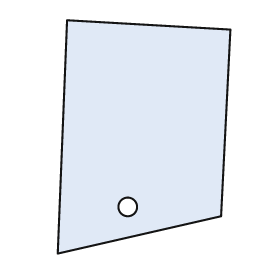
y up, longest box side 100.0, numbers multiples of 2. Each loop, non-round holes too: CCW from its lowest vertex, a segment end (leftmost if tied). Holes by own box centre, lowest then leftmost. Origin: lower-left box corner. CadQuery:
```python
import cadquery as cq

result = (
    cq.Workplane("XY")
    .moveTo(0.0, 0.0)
    .lineTo(70.0, 16.0)
    .lineTo(74.0, 96.0)
    .lineTo(4.0, 100.0)
    .close()
    .moveTo(30.0, 20.0)
    .circle(4.0)
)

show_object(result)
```